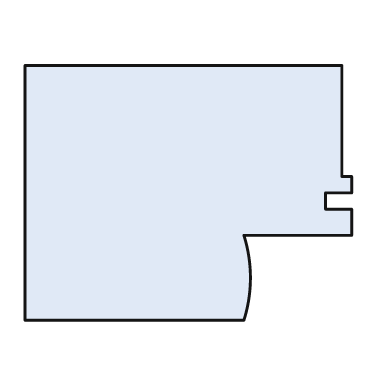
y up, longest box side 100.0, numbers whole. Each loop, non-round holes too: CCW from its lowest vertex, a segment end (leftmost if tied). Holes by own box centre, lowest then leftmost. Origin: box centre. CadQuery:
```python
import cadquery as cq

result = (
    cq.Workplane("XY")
    .moveTo(-50.0, -39.0)
    .lineTo(17.0, -39.0)
    .threePointArc((19.0, -26.0), (17.0, -13.0))
    .lineTo(50.0, -13.0)
    .lineTo(50.0, -5.0)
    .lineTo(42.0, -5.0)
    .lineTo(42.0, 0.0)
    .lineTo(50.0, 0.0)
    .lineTo(50.0, 5.0)
    .lineTo(47.0, 5.0)
    .lineTo(47.0, 39.0)
    .lineTo(-50.0, 39.0)
    .close()
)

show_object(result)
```